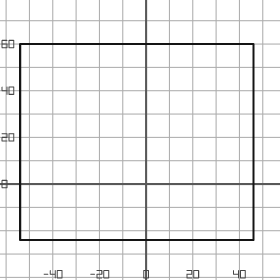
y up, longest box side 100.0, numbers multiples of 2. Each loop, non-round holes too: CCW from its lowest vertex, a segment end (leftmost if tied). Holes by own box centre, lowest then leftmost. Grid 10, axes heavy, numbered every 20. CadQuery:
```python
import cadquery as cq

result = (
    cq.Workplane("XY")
    .moveTo(-54.0, -24.0)
    .lineTo(46.0, -24.0)
    .lineTo(46.0, 60.0)
    .lineTo(-54.0, 60.0)
    .close()
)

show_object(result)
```